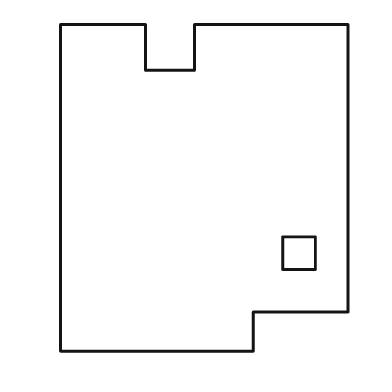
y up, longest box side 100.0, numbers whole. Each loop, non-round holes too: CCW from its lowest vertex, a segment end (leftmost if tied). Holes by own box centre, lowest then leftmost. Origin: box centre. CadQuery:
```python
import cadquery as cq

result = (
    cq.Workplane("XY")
    .moveTo(-44.0, -50.0)
    .lineTo(15.0, -50.0)
    .lineTo(15.0, -38.0)
    .lineTo(44.0, -38.0)
    .lineTo(44.0, 50.0)
    .lineTo(-3.0, 50.0)
    .lineTo(-3.0, 36.0)
    .lineTo(-18.0, 36.0)
    .lineTo(-18.0, 50.0)
    .lineTo(-44.0, 50.0)
    .close()
    .moveTo(24.0, -25.0)
    .lineTo(34.0, -25.0)
    .lineTo(34.0, -15.0)
    .lineTo(24.0, -15.0)
    .close()
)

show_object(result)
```